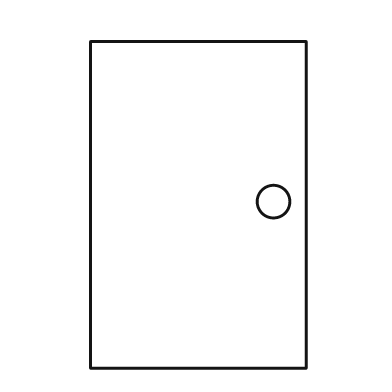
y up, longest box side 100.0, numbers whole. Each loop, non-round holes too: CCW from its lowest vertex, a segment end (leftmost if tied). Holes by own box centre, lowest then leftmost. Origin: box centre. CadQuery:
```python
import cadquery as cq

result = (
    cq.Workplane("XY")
    .moveTo(-33.0, -50.0)
    .lineTo(33.0, -50.0)
    .lineTo(33.0, 50.0)
    .lineTo(-33.0, 50.0)
    .close()
    .moveTo(23.0, 1.0)
    .circle(5.0)
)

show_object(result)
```